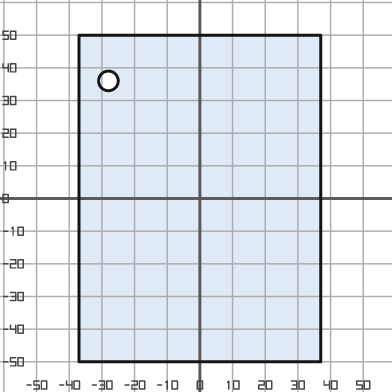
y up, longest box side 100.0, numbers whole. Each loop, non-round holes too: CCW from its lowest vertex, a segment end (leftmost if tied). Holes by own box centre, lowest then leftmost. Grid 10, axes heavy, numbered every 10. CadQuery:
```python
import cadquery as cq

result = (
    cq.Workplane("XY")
    .moveTo(-37.0, -50.0)
    .lineTo(37.0, -50.0)
    .lineTo(37.0, 50.0)
    .lineTo(-37.0, 50.0)
    .close()
    .moveTo(-28.0, 36.0)
    .circle(3.0)
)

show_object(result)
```